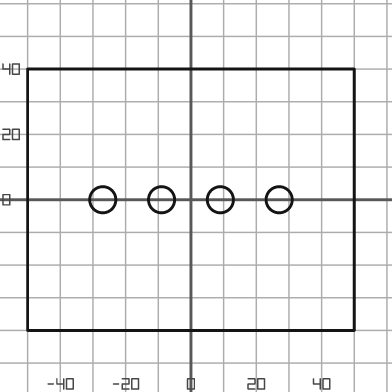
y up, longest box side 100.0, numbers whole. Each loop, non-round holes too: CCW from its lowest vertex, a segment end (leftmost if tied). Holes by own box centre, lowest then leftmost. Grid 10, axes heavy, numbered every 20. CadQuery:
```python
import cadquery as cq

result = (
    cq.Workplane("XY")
    .moveTo(-50.0, -40.0)
    .lineTo(50.0, -40.0)
    .lineTo(50.0, 40.0)
    .lineTo(-50.0, 40.0)
    .close()
    .moveTo(-27.0, 0.0)
    .circle(4.0)
    .moveTo(-9.0, 0.0)
    .circle(4.0)
    .moveTo(9.0, 0.0)
    .circle(4.0)
    .moveTo(27.0, 0.0)
    .circle(4.0)
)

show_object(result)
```